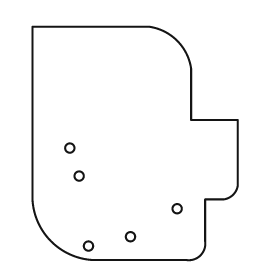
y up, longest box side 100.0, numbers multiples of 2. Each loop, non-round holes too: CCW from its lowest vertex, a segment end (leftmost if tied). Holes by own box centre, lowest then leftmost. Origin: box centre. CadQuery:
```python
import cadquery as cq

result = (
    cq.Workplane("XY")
    .moveTo(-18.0, -50.0)
    .lineTo(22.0, -50.0)
    .threePointArc((28.0, -48.0), (30.0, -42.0))
    .lineTo(30.0, -24.0)
    .lineTo(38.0, -24.0)
    .threePointArc((42.0, -22.0), (44.0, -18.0))
    .lineTo(44.0, 10.0)
    .lineTo(24.0, 10.0)
    .lineTo(24.0, 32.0)
    .threePointArc((18.0, 44.0), (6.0, 50.0))
    .lineTo(-44.0, 50.0)
    .lineTo(-44.0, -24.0)
    .threePointArc((-36.0, -42.0), (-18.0, -50.0))
    .close()
    .moveTo(-20.0, -44.0)
    .circle(2.0)
    .moveTo(-2.0, -40.0)
    .circle(2.0)
    .moveTo(18.0, -28.0)
    .circle(2.0)
    .moveTo(-24.0, -14.0)
    .circle(2.0)
    .moveTo(-28.0, -2.0)
    .circle(2.0)
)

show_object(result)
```